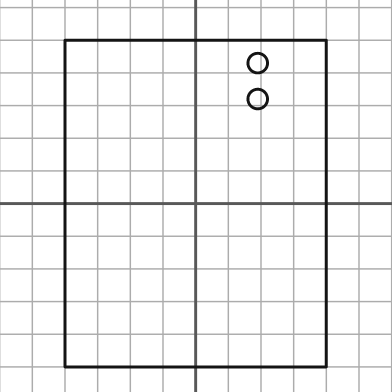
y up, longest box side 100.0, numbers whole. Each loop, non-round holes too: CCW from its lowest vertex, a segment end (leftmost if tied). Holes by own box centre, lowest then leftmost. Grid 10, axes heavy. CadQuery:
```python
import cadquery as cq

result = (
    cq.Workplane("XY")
    .moveTo(-40.0, -50.0)
    .lineTo(40.0, -50.0)
    .lineTo(40.0, 50.0)
    .lineTo(-40.0, 50.0)
    .close()
    .moveTo(19.0, 32.0)
    .circle(3.0)
    .moveTo(19.0, 43.0)
    .circle(3.0)
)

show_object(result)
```